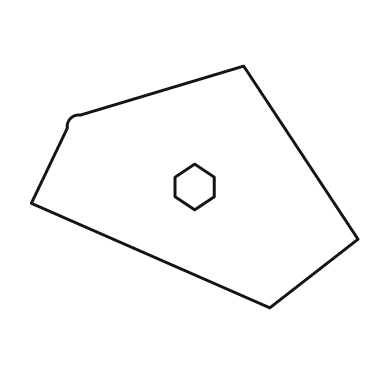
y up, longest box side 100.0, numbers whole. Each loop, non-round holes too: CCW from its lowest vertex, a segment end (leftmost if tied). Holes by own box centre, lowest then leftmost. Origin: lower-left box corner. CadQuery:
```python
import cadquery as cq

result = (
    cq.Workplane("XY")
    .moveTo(73.0, 0.0)
    .lineTo(100.0, 21.0)
    .lineTo(65.0, 74.0)
    .lineTo(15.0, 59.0)
    .threePointArc((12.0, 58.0), (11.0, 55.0))
    .lineTo(0.0, 32.0)
    .close()
    .moveTo(50.0, 30.0)
    .lineTo(56.0, 34.0)
    .lineTo(56.0, 40.0)
    .lineTo(50.0, 44.0)
    .lineTo(44.0, 40.0)
    .lineTo(44.0, 34.0)
    .close()
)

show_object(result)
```